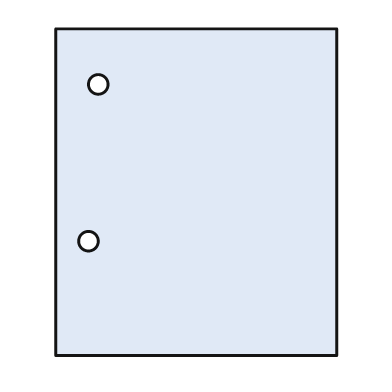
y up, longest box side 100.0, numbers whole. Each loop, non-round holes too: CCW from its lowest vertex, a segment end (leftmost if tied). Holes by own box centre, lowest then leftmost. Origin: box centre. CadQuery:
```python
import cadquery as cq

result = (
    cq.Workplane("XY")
    .moveTo(-43.0, -50.0)
    .lineTo(43.0, -50.0)
    .lineTo(43.0, 50.0)
    .lineTo(-43.0, 50.0)
    .close()
    .moveTo(-33.0, -15.0)
    .circle(3.0)
    .moveTo(-30.0, 33.0)
    .circle(3.0)
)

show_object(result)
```